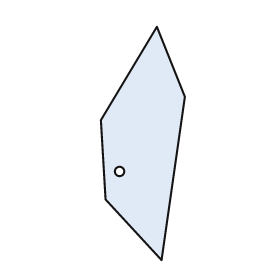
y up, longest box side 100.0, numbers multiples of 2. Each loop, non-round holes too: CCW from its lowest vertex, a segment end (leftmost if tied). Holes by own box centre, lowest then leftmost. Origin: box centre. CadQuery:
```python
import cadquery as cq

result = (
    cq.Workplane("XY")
    .moveTo(8.0, -50.0)
    .lineTo(18.0, 20.0)
    .lineTo(6.0, 50.0)
    .lineTo(-18.0, 10.0)
    .lineTo(-16.0, -24.0)
    .close()
    .moveTo(-10.0, -12.0)
    .circle(2.0)
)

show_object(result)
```